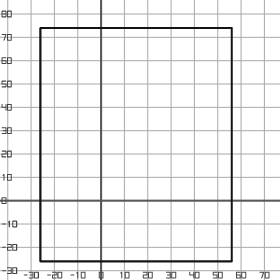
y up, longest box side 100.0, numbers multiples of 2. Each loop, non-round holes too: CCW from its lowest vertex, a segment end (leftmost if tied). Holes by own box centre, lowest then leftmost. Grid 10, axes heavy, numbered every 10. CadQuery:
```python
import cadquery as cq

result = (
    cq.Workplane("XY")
    .moveTo(-26.0, -26.0)
    .lineTo(56.0, -26.0)
    .lineTo(56.0, 74.0)
    .lineTo(-26.0, 74.0)
    .close()
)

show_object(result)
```